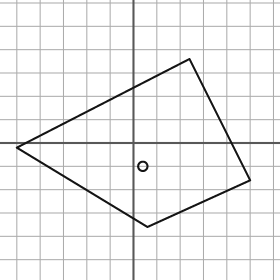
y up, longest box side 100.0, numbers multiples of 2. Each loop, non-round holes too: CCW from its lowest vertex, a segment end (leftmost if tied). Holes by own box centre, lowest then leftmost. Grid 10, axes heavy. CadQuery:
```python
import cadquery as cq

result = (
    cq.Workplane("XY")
    .moveTo(6.0, -36.0)
    .lineTo(50.0, -16.0)
    .lineTo(24.0, 36.0)
    .lineTo(-50.0, -2.0)
    .close()
    .moveTo(4.0, -10.0)
    .circle(2.0)
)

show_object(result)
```